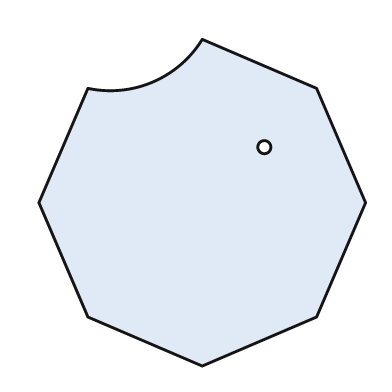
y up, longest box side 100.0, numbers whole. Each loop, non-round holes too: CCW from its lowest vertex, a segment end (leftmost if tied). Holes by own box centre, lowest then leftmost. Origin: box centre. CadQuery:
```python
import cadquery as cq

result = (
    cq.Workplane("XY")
    .moveTo(0.0, -50.0)
    .lineTo(35.0, -35.0)
    .lineTo(50.0, 0.0)
    .lineTo(35.0, 35.0)
    .lineTo(0.0, 50.0)
    .threePointArc((-15.0, 37.0), (-35.0, 35.0))
    .lineTo(-50.0, 0.0)
    .lineTo(-35.0, -35.0)
    .close()
    .moveTo(19.0, 17.0)
    .circle(2.0)
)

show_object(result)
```